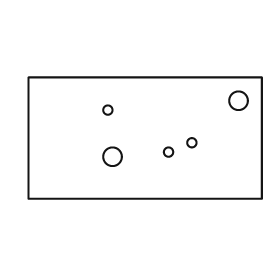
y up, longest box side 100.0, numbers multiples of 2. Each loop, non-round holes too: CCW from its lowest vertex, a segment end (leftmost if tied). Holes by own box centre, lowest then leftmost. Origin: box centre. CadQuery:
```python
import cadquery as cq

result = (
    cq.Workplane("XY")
    .moveTo(-50.0, -26.0)
    .lineTo(50.0, -26.0)
    .lineTo(50.0, 26.0)
    .lineTo(-50.0, 26.0)
    .close()
    .moveTo(-14.0, -8.0)
    .circle(4.0)
    .moveTo(10.0, -6.0)
    .circle(2.0)
    .moveTo(20.0, -2.0)
    .circle(2.0)
    .moveTo(-16.0, 12.0)
    .circle(2.0)
    .moveTo(40.0, 16.0)
    .circle(4.0)
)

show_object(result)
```